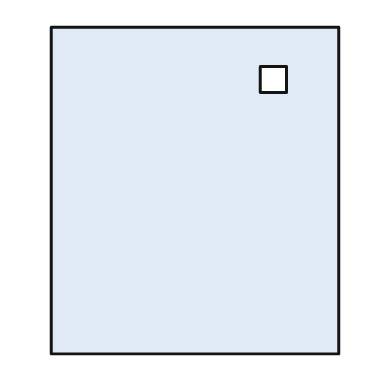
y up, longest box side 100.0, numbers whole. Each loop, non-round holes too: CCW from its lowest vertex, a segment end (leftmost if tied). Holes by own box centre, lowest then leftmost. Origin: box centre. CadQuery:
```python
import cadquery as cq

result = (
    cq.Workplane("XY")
    .moveTo(-44.0, -50.0)
    .lineTo(44.0, -50.0)
    .lineTo(44.0, 50.0)
    .lineTo(-44.0, 50.0)
    .close()
    .moveTo(20.0, 30.0)
    .lineTo(28.0, 30.0)
    .lineTo(28.0, 38.0)
    .lineTo(20.0, 38.0)
    .close()
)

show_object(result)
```